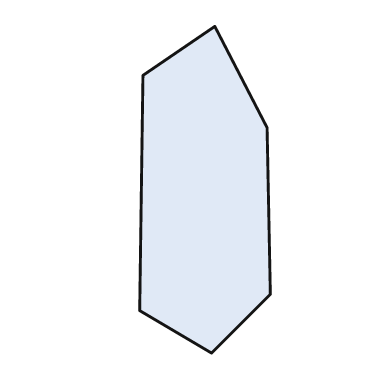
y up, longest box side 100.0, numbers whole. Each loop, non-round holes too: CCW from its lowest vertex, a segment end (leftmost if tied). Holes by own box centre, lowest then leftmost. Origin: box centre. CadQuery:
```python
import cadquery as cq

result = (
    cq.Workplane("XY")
    .moveTo(2.0, -50.0)
    .lineTo(20.0, -32.0)
    .lineTo(19.0, 19.0)
    .lineTo(3.0, 50.0)
    .lineTo(-19.0, 35.0)
    .lineTo(-20.0, -37.0)
    .close()
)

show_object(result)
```